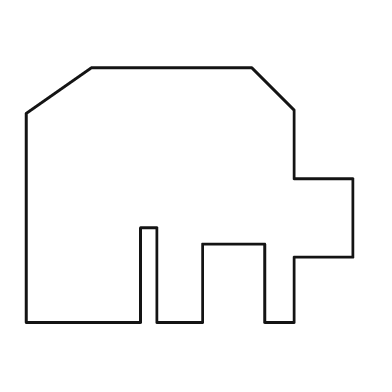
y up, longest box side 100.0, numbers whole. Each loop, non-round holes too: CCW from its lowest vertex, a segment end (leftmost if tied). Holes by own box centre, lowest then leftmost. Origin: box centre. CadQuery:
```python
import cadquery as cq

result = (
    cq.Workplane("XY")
    .moveTo(-50.0, -39.0)
    .lineTo(-15.0, -39.0)
    .lineTo(-15.0, -10.0)
    .lineTo(-10.0, -10.0)
    .lineTo(-10.0, -39.0)
    .lineTo(4.0, -39.0)
    .lineTo(4.0, -15.0)
    .lineTo(23.0, -15.0)
    .lineTo(23.0, -39.0)
    .lineTo(32.0, -39.0)
    .lineTo(32.0, -19.0)
    .lineTo(50.0, -19.0)
    .lineTo(50.0, 5.0)
    .lineTo(32.0, 5.0)
    .lineTo(32.0, 26.0)
    .lineTo(19.0, 39.0)
    .lineTo(-30.0, 39.0)
    .lineTo(-50.0, 25.0)
    .close()
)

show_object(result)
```